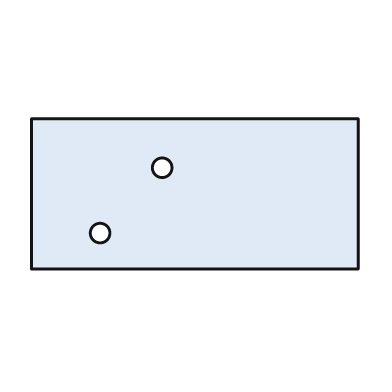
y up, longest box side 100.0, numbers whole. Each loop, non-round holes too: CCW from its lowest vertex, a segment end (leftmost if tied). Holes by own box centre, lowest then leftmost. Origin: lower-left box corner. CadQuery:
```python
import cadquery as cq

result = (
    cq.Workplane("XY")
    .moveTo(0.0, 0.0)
    .lineTo(100.0, 0.0)
    .lineTo(100.0, 46.0)
    .lineTo(0.0, 46.0)
    .close()
    .moveTo(21.0, 11.0)
    .circle(3.0)
    .moveTo(40.0, 31.0)
    .circle(3.0)
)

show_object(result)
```